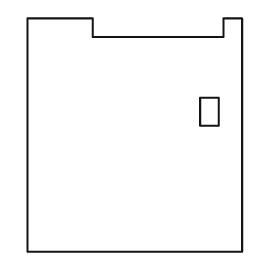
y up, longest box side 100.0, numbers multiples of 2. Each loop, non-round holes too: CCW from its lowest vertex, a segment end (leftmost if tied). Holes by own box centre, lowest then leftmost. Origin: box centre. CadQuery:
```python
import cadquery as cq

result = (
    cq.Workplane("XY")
    .moveTo(-46.0, -50.0)
    .lineTo(46.0, -50.0)
    .lineTo(46.0, 50.0)
    .lineTo(38.0, 50.0)
    .lineTo(38.0, 42.0)
    .lineTo(-18.0, 42.0)
    .lineTo(-18.0, 50.0)
    .lineTo(-46.0, 50.0)
    .close()
    .moveTo(28.0, 4.0)
    .lineTo(36.0, 4.0)
    .lineTo(36.0, 16.0)
    .lineTo(28.0, 16.0)
    .close()
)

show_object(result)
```